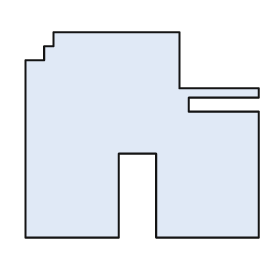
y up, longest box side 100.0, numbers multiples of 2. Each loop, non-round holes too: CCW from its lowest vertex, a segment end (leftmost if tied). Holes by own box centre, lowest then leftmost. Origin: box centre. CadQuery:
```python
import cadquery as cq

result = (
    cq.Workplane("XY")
    .moveTo(-50.0, -44.0)
    .lineTo(-10.0, -44.0)
    .lineTo(-10.0, -8.0)
    .lineTo(6.0, -8.0)
    .lineTo(6.0, -44.0)
    .lineTo(50.0, -44.0)
    .lineTo(50.0, 10.0)
    .lineTo(20.0, 10.0)
    .lineTo(20.0, 16.0)
    .lineTo(50.0, 16.0)
    .lineTo(50.0, 20.0)
    .lineTo(16.0, 20.0)
    .lineTo(16.0, 44.0)
    .lineTo(-38.0, 44.0)
    .lineTo(-38.0, 38.0)
    .lineTo(-42.0, 38.0)
    .lineTo(-42.0, 32.0)
    .lineTo(-50.0, 32.0)
    .close()
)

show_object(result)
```